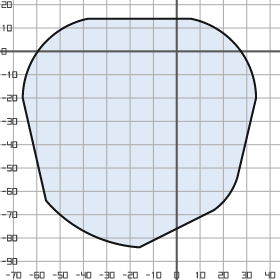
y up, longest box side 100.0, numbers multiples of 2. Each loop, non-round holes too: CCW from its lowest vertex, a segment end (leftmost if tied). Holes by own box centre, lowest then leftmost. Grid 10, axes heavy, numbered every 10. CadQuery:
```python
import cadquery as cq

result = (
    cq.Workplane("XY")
    .moveTo(-16.0, -84.0)
    .lineTo(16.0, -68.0)
    .threePointArc((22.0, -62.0), (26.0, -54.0))
    .lineTo(34.0, -20.0)
    .threePointArc((26.0, 2.0), (6.0, 14.0))
    .lineTo(-38.0, 14.0)
    .threePointArc((-58.0, 2.0), (-66.0, -20.0))
    .lineTo(-56.0, -64.0)
    .threePointArc((-38.0, -78.0), (-16.0, -84.0))
    .close()
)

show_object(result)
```